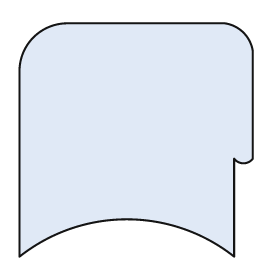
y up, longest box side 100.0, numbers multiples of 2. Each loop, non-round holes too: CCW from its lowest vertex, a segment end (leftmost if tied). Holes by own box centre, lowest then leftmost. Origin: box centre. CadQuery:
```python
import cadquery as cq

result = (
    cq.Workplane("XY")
    .moveTo(-50.0, -50.0)
    .threePointArc((-4.0, -34.0), (42.0, -50.0))
    .lineTo(42.0, -8.0)
    .threePointArc((46.0, -10.0), (50.0, -8.0))
    .lineTo(50.0, 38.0)
    .threePointArc((46.0, 46.0), (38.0, 50.0))
    .lineTo(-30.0, 50.0)
    .threePointArc((-44.0, 44.0), (-50.0, 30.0))
    .close()
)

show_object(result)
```